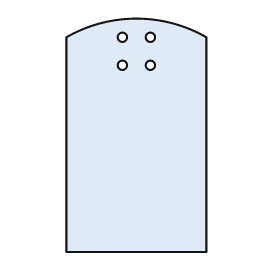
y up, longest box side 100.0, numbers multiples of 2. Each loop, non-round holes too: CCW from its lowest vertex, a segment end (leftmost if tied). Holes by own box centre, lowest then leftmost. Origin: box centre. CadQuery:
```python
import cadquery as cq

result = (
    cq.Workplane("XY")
    .moveTo(-30.0, -50.0)
    .lineTo(30.0, -50.0)
    .lineTo(30.0, 42.0)
    .threePointArc((0.0, 50.0), (-30.0, 42.0))
    .close()
    .moveTo(-6.0, 30.0)
    .circle(2.0)
    .moveTo(6.0, 30.0)
    .circle(2.0)
    .moveTo(-6.0, 42.0)
    .circle(2.0)
    .moveTo(6.0, 42.0)
    .circle(2.0)
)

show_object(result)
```